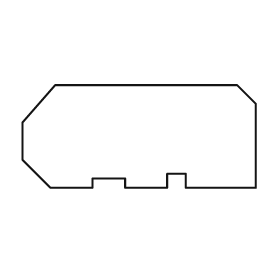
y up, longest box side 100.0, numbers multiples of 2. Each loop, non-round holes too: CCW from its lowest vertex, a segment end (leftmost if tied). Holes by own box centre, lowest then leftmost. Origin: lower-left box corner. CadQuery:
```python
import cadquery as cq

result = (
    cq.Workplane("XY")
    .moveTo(12.0, 0.0)
    .lineTo(30.0, 0.0)
    .lineTo(30.0, 4.0)
    .lineTo(44.0, 4.0)
    .lineTo(44.0, 0.0)
    .lineTo(62.0, 0.0)
    .lineTo(62.0, 6.0)
    .lineTo(70.0, 6.0)
    .lineTo(70.0, 0.0)
    .lineTo(100.0, 0.0)
    .lineTo(100.0, 36.0)
    .lineTo(92.0, 44.0)
    .lineTo(14.0, 44.0)
    .lineTo(0.0, 28.0)
    .lineTo(0.0, 12.0)
    .close()
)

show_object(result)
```